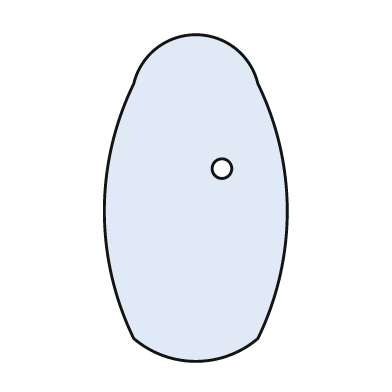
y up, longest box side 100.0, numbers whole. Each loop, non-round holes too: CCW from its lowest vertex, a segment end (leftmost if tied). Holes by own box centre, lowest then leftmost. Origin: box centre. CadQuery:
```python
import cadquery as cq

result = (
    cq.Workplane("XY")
    .moveTo(-19.0, -43.0)
    .threePointArc((0.0, -50.0), (19.0, -43.0))
    .threePointArc((28.0, -4.0), (19.0, 35.0))
    .threePointArc((0.0, 50.0), (-19.0, 35.0))
    .threePointArc((-28.0, -4.0), (-19.0, -43.0))
    .close()
    .moveTo(8.0, 9.0)
    .circle(3.0)
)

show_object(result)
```